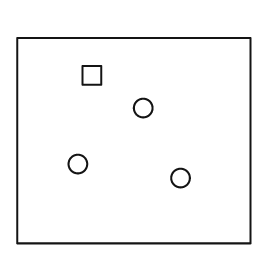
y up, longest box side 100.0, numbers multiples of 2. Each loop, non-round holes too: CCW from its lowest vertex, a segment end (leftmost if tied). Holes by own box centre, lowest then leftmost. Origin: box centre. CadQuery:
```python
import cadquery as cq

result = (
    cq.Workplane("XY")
    .moveTo(-50.0, -44.0)
    .lineTo(50.0, -44.0)
    .lineTo(50.0, 44.0)
    .lineTo(-50.0, 44.0)
    .close()
    .moveTo(20.0, -16.0)
    .circle(4.0)
    .moveTo(-24.0, -10.0)
    .circle(4.0)
    .moveTo(4.0, 14.0)
    .circle(4.0)
    .moveTo(-22.0, 24.0)
    .lineTo(-14.0, 24.0)
    .lineTo(-14.0, 32.0)
    .lineTo(-22.0, 32.0)
    .close()
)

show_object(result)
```